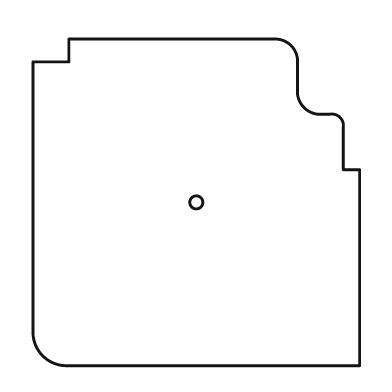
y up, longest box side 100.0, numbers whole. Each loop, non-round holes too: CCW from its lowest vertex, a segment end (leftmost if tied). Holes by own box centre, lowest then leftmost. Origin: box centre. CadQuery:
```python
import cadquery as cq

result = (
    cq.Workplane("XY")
    .moveTo(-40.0, -50.0)
    .lineTo(50.0, -50.0)
    .lineTo(50.0, 10.0)
    .lineTo(45.0, 10.0)
    .lineTo(45.0, 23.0)
    .threePointArc((44.0, 26.0), (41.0, 27.0))
    .lineTo(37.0, 27.0)
    .threePointArc((33.0, 29.0), (31.0, 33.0))
    .lineTo(31.0, 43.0)
    .threePointArc((29.0, 48.0), (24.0, 50.0))
    .lineTo(-39.0, 50.0)
    .lineTo(-39.0, 43.0)
    .lineTo(-50.0, 43.0)
    .lineTo(-50.0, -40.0)
    .threePointArc((-47.0, -47.0), (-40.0, -50.0))
    .close()
    .moveTo(0.0, 0.0)
    .circle(2.0)
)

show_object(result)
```